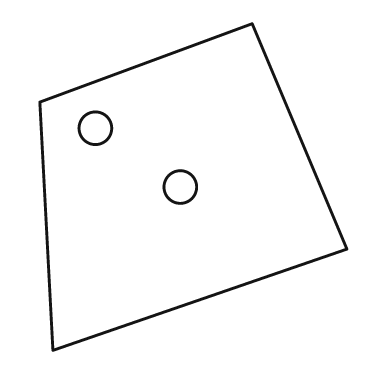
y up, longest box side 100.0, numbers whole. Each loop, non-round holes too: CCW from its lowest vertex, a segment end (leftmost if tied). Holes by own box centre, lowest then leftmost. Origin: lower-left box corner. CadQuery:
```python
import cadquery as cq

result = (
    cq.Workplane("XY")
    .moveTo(4.0, 0.0)
    .lineTo(94.0, 31.0)
    .lineTo(65.0, 100.0)
    .lineTo(0.0, 76.0)
    .close()
    .moveTo(43.0, 50.0)
    .circle(5.0)
    .moveTo(17.0, 68.0)
    .circle(5.0)
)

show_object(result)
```